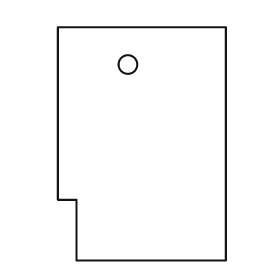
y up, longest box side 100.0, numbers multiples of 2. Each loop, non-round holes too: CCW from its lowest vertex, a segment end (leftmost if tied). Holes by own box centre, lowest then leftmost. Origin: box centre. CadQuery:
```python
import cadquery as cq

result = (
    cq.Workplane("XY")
    .moveTo(-28.0, -50.0)
    .lineTo(36.0, -50.0)
    .lineTo(36.0, 50.0)
    .lineTo(-36.0, 50.0)
    .lineTo(-36.0, -24.0)
    .lineTo(-28.0, -24.0)
    .close()
    .moveTo(-6.0, 34.0)
    .circle(4.0)
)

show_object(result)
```